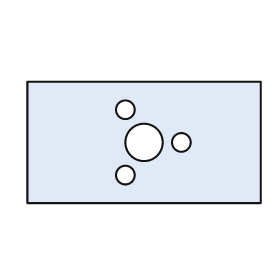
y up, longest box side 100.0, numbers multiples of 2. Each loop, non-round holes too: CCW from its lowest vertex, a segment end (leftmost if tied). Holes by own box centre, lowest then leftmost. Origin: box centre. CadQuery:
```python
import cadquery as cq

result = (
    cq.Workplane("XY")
    .moveTo(-50.0, -26.0)
    .lineTo(50.0, -26.0)
    .lineTo(50.0, 26.0)
    .lineTo(-50.0, 26.0)
    .close()
    .moveTo(-8.0, -14.0)
    .circle(4.0)
    .moveTo(0.0, 0.0)
    .circle(8.0)
    .moveTo(16.0, 0.0)
    .circle(4.0)
    .moveTo(-8.0, 14.0)
    .circle(4.0)
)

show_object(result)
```